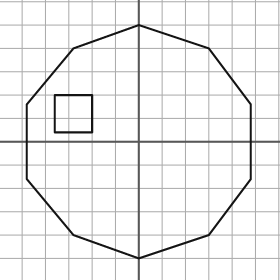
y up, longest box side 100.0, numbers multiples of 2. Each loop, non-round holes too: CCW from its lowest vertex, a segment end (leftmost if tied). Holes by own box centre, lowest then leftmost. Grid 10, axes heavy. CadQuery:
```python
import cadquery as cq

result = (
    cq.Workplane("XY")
    .moveTo(0.0, -50.0)
    .lineTo(30.0, -40.0)
    .lineTo(48.0, -16.0)
    .lineTo(48.0, 16.0)
    .lineTo(30.0, 40.0)
    .lineTo(0.0, 50.0)
    .lineTo(-28.0, 40.0)
    .lineTo(-48.0, 16.0)
    .lineTo(-48.0, -16.0)
    .lineTo(-28.0, -40.0)
    .close()
    .moveTo(-36.0, 4.0)
    .lineTo(-20.0, 4.0)
    .lineTo(-20.0, 20.0)
    .lineTo(-36.0, 20.0)
    .close()
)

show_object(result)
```